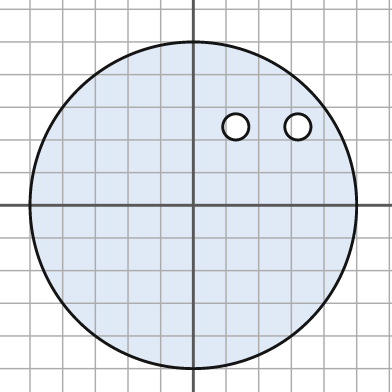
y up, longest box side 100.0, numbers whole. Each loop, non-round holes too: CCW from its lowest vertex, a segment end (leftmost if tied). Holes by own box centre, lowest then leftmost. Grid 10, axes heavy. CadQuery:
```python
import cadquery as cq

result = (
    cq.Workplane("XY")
    .moveTo(0.0, 0.0)
    .circle(50.0)
    .moveTo(13.0, 24.0)
    .circle(4.0)
    .moveTo(32.0, 24.0)
    .circle(4.0)
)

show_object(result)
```